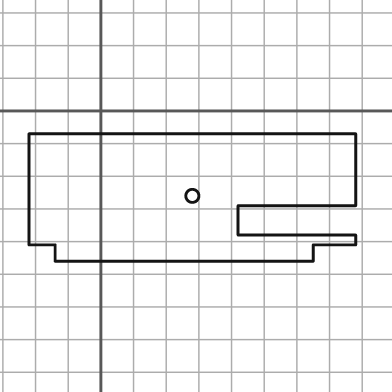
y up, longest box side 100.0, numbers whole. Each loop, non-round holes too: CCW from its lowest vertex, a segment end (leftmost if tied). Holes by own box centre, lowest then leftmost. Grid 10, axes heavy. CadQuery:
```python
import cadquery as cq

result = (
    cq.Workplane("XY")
    .moveTo(-14.0, -46.0)
    .lineTo(65.0, -46.0)
    .lineTo(65.0, -41.0)
    .lineTo(78.0, -41.0)
    .lineTo(78.0, -38.0)
    .lineTo(42.0, -38.0)
    .lineTo(42.0, -29.0)
    .lineTo(78.0, -29.0)
    .lineTo(78.0, -7.0)
    .lineTo(-22.0, -7.0)
    .lineTo(-22.0, -41.0)
    .lineTo(-14.0, -41.0)
    .close()
    .moveTo(28.0, -26.0)
    .circle(2.0)
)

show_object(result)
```